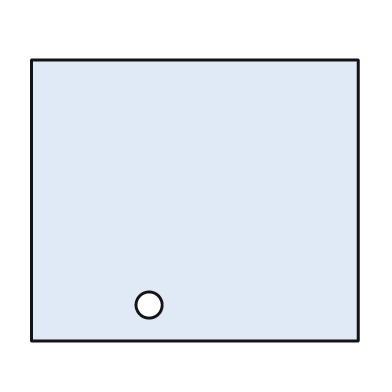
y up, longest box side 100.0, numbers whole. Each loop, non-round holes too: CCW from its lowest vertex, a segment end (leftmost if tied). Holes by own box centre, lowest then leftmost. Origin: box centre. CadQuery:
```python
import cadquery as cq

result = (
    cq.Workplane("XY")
    .moveTo(-50.0, -43.0)
    .lineTo(50.0, -43.0)
    .lineTo(50.0, 43.0)
    .lineTo(-50.0, 43.0)
    .close()
    .moveTo(-14.0, -32.0)
    .circle(4.0)
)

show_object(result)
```